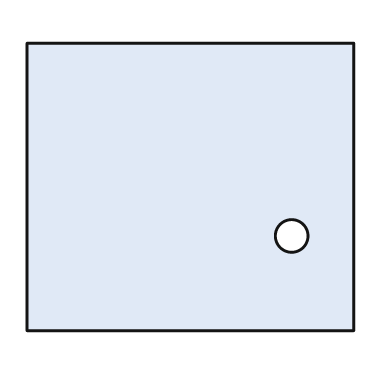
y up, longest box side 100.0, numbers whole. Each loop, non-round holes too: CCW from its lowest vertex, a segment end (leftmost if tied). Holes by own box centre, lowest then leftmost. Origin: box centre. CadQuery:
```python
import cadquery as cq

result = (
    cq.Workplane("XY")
    .moveTo(-50.0, -44.0)
    .lineTo(50.0, -44.0)
    .lineTo(50.0, 44.0)
    .lineTo(-50.0, 44.0)
    .close()
    .moveTo(31.0, -15.0)
    .circle(5.0)
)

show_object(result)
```